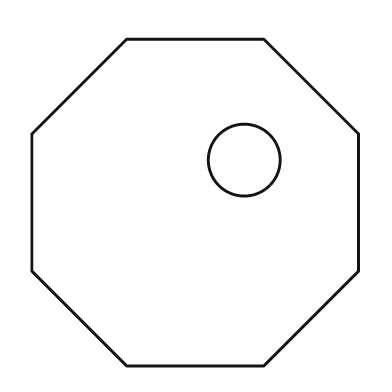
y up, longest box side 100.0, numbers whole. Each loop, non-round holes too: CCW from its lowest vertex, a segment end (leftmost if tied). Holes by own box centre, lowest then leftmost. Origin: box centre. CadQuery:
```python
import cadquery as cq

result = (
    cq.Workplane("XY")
    .moveTo(-21.0, -50.0)
    .lineTo(21.0, -50.0)
    .lineTo(50.0, -21.0)
    .lineTo(50.0, 21.0)
    .lineTo(21.0, 50.0)
    .lineTo(-21.0, 50.0)
    .lineTo(-50.0, 21.0)
    .lineTo(-50.0, -21.0)
    .close()
    .moveTo(15.0, 13.0)
    .circle(11.0)
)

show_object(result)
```